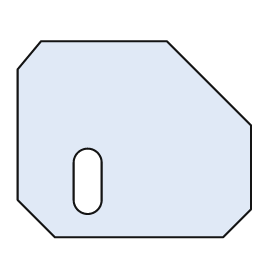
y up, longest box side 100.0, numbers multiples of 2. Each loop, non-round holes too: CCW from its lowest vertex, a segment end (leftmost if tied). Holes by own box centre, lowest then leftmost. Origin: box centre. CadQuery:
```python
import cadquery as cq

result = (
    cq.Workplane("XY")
    .moveTo(-34.0, -42.0)
    .lineTo(38.0, -42.0)
    .lineTo(50.0, -30.0)
    .lineTo(50.0, 6.0)
    .lineTo(14.0, 42.0)
    .lineTo(-40.0, 42.0)
    .lineTo(-50.0, 30.0)
    .lineTo(-50.0, -26.0)
    .close()
    .moveTo(-26.0, -26.0)
    .threePointArc((-20.0, -32.0), (-14.0, -26.0))
    .lineTo(-14.0, -10.0)
    .threePointArc((-20.0, -4.0), (-26.0, -10.0))
    .close()
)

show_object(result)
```